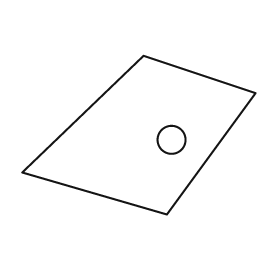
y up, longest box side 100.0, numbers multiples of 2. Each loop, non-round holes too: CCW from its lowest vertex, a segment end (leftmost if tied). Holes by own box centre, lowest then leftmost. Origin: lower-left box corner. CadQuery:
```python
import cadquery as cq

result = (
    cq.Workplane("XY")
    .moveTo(62.0, 0.0)
    .lineTo(100.0, 52.0)
    .lineTo(52.0, 68.0)
    .lineTo(0.0, 18.0)
    .close()
    .moveTo(64.0, 32.0)
    .circle(6.0)
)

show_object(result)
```